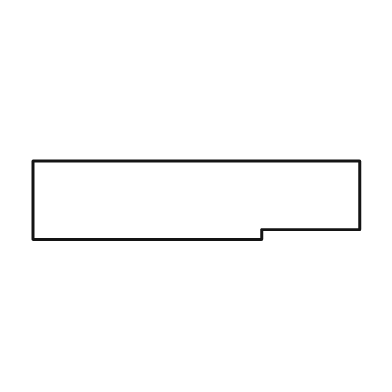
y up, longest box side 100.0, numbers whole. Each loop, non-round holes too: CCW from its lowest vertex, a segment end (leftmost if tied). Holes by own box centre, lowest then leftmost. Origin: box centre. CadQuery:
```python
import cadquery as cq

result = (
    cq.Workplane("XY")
    .moveTo(-50.0, -12.0)
    .lineTo(20.0, -12.0)
    .lineTo(20.0, -9.0)
    .lineTo(50.0, -9.0)
    .lineTo(50.0, 12.0)
    .lineTo(-50.0, 12.0)
    .close()
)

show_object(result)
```